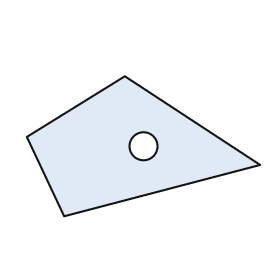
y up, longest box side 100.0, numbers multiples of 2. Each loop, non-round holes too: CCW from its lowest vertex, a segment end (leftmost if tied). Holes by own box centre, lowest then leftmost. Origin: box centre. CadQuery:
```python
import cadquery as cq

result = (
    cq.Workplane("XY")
    .moveTo(-34.0, -30.0)
    .lineTo(50.0, -8.0)
    .lineTo(-8.0, 30.0)
    .lineTo(-50.0, 4.0)
    .close()
    .moveTo(0.0, 0.0)
    .circle(6.0)
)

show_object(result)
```